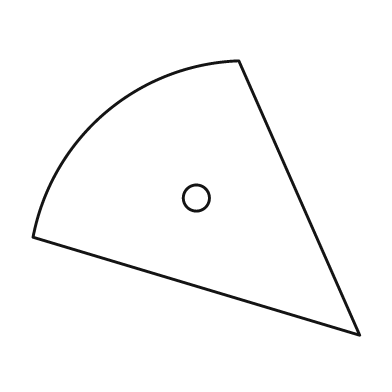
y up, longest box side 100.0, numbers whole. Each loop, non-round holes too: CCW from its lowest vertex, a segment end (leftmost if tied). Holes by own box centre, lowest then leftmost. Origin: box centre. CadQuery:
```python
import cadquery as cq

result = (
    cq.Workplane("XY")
    .moveTo(50.0, -42.0)
    .lineTo(13.0, 42.0)
    .threePointArc((-28.0, 26.0), (-50.0, -12.0))
    .close()
    .moveTo(0.0, 0.0)
    .circle(4.0)
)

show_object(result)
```